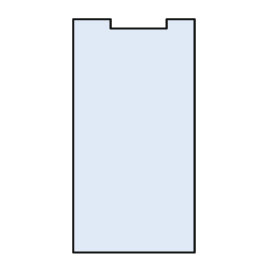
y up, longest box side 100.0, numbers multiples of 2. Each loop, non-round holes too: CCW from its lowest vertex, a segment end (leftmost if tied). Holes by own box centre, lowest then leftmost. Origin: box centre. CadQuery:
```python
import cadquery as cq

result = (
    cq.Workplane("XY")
    .moveTo(-26.0, -50.0)
    .lineTo(26.0, -50.0)
    .lineTo(26.0, 50.0)
    .lineTo(14.0, 50.0)
    .lineTo(14.0, 46.0)
    .lineTo(-10.0, 46.0)
    .lineTo(-10.0, 50.0)
    .lineTo(-26.0, 50.0)
    .close()
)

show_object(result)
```